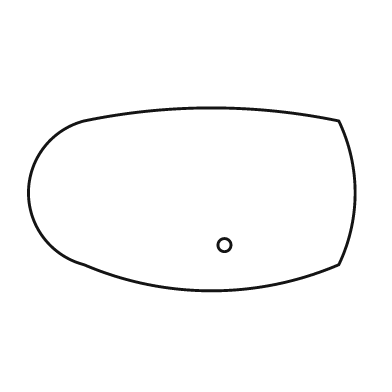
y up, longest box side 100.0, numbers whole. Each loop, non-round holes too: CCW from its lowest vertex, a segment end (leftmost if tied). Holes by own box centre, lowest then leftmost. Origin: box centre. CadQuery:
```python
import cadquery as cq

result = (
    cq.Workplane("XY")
    .moveTo(-33.0, -20.0)
    .threePointArc((6.0, -28.0), (45.0, -20.0))
    .threePointArc((50.0, 2.0), (45.0, 24.0))
    .threePointArc((6.0, 28.0), (-33.0, 24.0))
    .threePointArc((-50.0, 2.0), (-33.0, -20.0))
    .close()
    .moveTo(10.0, -14.0)
    .circle(2.0)
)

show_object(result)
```